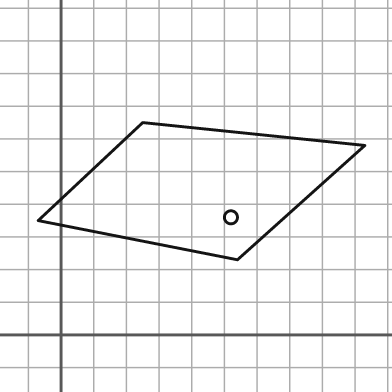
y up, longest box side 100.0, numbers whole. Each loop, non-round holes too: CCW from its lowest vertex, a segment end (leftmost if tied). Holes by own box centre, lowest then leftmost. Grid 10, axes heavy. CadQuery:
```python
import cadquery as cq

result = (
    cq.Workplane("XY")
    .moveTo(54.0, 23.0)
    .lineTo(93.0, 58.0)
    .lineTo(25.0, 65.0)
    .lineTo(-7.0, 35.0)
    .close()
    .moveTo(52.0, 36.0)
    .circle(2.0)
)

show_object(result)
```